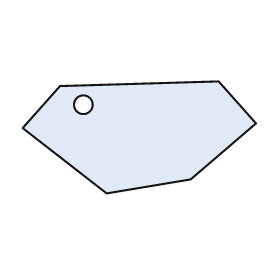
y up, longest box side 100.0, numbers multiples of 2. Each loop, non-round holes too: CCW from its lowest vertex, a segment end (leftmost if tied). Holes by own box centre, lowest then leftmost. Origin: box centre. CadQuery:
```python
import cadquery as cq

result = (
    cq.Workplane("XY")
    .moveTo(-14.0, -24.0)
    .lineTo(22.0, -18.0)
    .lineTo(50.0, 6.0)
    .lineTo(34.0, 24.0)
    .lineTo(-34.0, 22.0)
    .lineTo(-50.0, 4.0)
    .close()
    .moveTo(-24.0, 14.0)
    .circle(4.0)
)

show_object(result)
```